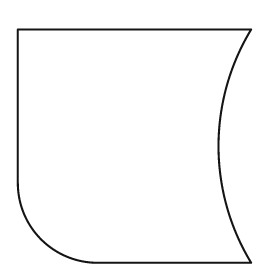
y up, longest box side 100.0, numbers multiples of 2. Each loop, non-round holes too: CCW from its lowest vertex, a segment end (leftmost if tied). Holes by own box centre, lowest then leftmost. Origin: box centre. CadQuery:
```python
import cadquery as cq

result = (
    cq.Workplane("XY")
    .moveTo(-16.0, -50.0)
    .lineTo(50.0, -50.0)
    .threePointArc((36.0, 0.0), (50.0, 50.0))
    .lineTo(-50.0, 50.0)
    .lineTo(-50.0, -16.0)
    .threePointArc((-40.0, -40.0), (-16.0, -50.0))
    .close()
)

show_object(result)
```